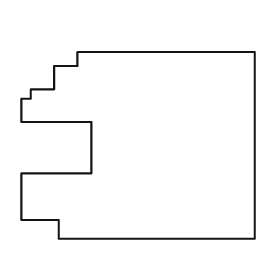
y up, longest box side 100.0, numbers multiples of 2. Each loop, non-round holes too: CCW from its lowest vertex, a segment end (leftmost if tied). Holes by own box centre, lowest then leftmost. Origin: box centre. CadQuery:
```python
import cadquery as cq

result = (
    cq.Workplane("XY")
    .moveTo(-34.0, -40.0)
    .lineTo(50.0, -40.0)
    .lineTo(50.0, 40.0)
    .lineTo(-26.0, 40.0)
    .lineTo(-26.0, 34.0)
    .lineTo(-36.0, 34.0)
    .lineTo(-36.0, 24.0)
    .lineTo(-46.0, 24.0)
    .lineTo(-46.0, 20.0)
    .lineTo(-50.0, 20.0)
    .lineTo(-50.0, 10.0)
    .lineTo(-20.0, 10.0)
    .lineTo(-20.0, -12.0)
    .lineTo(-50.0, -12.0)
    .lineTo(-50.0, -32.0)
    .lineTo(-34.0, -32.0)
    .close()
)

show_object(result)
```